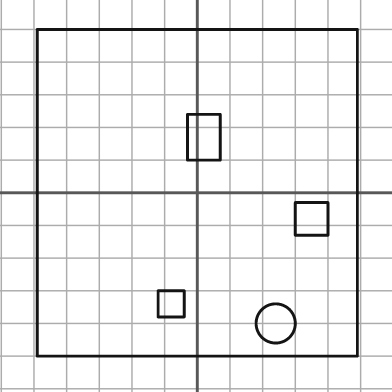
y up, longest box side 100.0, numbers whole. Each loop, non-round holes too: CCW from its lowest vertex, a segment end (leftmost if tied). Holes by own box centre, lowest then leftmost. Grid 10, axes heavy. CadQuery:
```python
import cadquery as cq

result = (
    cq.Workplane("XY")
    .moveTo(-49.0, -50.0)
    .lineTo(49.0, -50.0)
    .lineTo(49.0, 50.0)
    .lineTo(-49.0, 50.0)
    .close()
    .moveTo(24.0, -40.0)
    .circle(6.0)
    .moveTo(-12.0, -38.0)
    .lineTo(-4.0, -38.0)
    .lineTo(-4.0, -30.0)
    .lineTo(-12.0, -30.0)
    .close()
    .moveTo(30.0, -13.0)
    .lineTo(40.0, -13.0)
    .lineTo(40.0, -3.0)
    .lineTo(30.0, -3.0)
    .close()
    .moveTo(-3.0, 10.0)
    .lineTo(7.0, 10.0)
    .lineTo(7.0, 24.0)
    .lineTo(-3.0, 24.0)
    .close()
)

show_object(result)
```